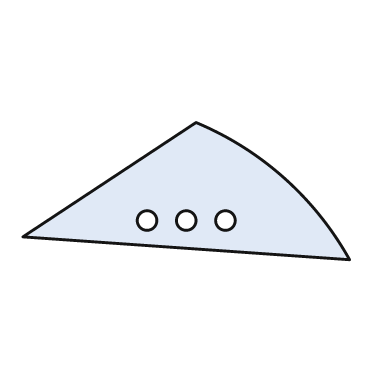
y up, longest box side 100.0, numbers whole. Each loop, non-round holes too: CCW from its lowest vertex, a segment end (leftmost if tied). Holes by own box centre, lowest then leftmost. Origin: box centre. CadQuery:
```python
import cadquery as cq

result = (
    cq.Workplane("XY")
    .moveTo(50.0, -21.0)
    .threePointArc((30.0, 4.0), (3.0, 21.0))
    .lineTo(-50.0, -14.0)
    .close()
    .moveTo(-12.0, -9.0)
    .circle(3.0)
    .moveTo(0.0, -9.0)
    .circle(3.0)
    .moveTo(12.0, -9.0)
    .circle(3.0)
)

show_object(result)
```